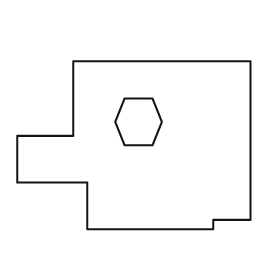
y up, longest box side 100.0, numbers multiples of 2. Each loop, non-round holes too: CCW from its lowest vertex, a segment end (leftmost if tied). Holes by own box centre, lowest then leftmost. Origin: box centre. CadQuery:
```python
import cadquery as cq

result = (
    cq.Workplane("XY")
    .moveTo(-20.0, -36.0)
    .lineTo(34.0, -36.0)
    .lineTo(34.0, -32.0)
    .lineTo(50.0, -32.0)
    .lineTo(50.0, 36.0)
    .lineTo(-26.0, 36.0)
    .lineTo(-26.0, 4.0)
    .lineTo(-50.0, 4.0)
    .lineTo(-50.0, -16.0)
    .lineTo(-20.0, -16.0)
    .close()
    .moveTo(-4.0, 0.0)
    .lineTo(8.0, 0.0)
    .lineTo(12.0, 10.0)
    .lineTo(8.0, 20.0)
    .lineTo(-4.0, 20.0)
    .lineTo(-8.0, 10.0)
    .close()
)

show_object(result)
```